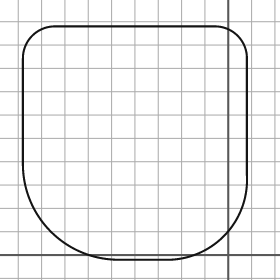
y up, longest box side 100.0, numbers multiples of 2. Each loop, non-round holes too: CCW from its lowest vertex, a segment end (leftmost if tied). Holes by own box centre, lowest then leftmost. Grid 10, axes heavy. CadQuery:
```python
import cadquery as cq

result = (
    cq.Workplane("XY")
    .moveTo(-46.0, -2.0)
    .lineTo(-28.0, -2.0)
    .threePointArc((-2.0, 8.0), (8.0, 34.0))
    .lineTo(8.0, 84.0)
    .threePointArc((4.0, 94.0), (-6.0, 98.0))
    .lineTo(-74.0, 98.0)
    .threePointArc((-84.0, 94.0), (-88.0, 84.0))
    .lineTo(-88.0, 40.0)
    .threePointArc((-76.0, 10.0), (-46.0, -2.0))
    .close()
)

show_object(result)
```